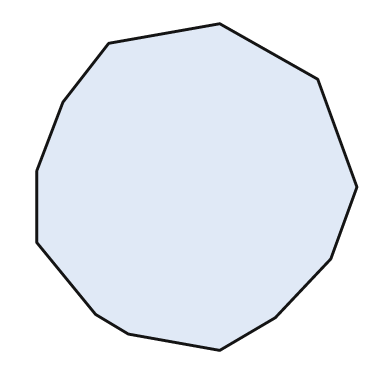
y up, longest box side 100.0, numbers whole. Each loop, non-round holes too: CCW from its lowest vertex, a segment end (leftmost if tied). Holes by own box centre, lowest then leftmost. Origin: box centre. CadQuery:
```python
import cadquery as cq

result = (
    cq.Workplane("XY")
    .moveTo(7.0, -50.0)
    .lineTo(24.0, -40.0)
    .lineTo(41.0, -22.0)
    .lineTo(49.0, 0.0)
    .lineTo(37.0, 33.0)
    .lineTo(7.0, 50.0)
    .lineTo(-27.0, 44.0)
    .lineTo(-41.0, 26.0)
    .lineTo(-49.0, 5.0)
    .lineTo(-49.0, -17.0)
    .lineTo(-31.0, -39.0)
    .lineTo(-21.0, -45.0)
    .close()
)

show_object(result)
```